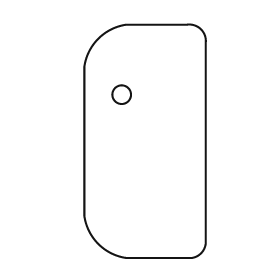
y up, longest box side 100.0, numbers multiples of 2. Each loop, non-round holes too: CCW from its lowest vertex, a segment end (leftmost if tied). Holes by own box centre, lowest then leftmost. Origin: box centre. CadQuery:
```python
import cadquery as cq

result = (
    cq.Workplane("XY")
    .moveTo(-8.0, -50.0)
    .lineTo(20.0, -50.0)
    .threePointArc((24.0, -48.0), (26.0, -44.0))
    .lineTo(26.0, 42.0)
    .threePointArc((24.0, 48.0), (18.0, 50.0))
    .lineTo(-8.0, 50.0)
    .threePointArc((-20.0, 44.0), (-26.0, 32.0))
    .lineTo(-26.0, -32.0)
    .threePointArc((-20.0, -44.0), (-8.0, -50.0))
    .close()
    .moveTo(-10.0, 20.0)
    .circle(4.0)
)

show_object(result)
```